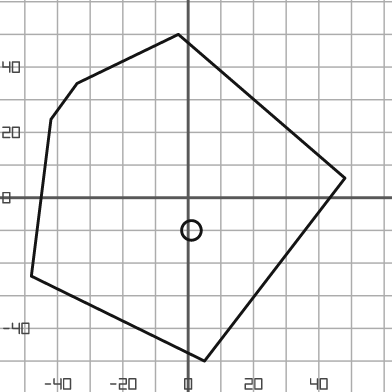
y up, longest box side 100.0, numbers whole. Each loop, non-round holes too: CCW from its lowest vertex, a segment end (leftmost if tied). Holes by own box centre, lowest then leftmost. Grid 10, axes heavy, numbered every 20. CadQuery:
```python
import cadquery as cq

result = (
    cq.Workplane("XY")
    .moveTo(5.0, -50.0)
    .lineTo(48.0, 6.0)
    .lineTo(-3.0, 50.0)
    .lineTo(-34.0, 35.0)
    .lineTo(-42.0, 24.0)
    .lineTo(-48.0, -24.0)
    .close()
    .moveTo(1.0, -10.0)
    .circle(3.0)
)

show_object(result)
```